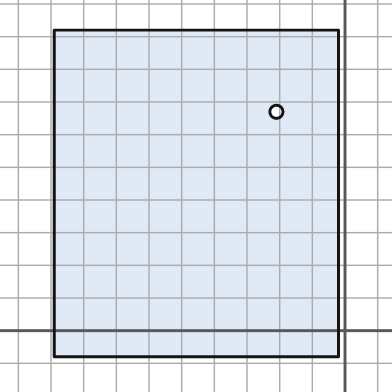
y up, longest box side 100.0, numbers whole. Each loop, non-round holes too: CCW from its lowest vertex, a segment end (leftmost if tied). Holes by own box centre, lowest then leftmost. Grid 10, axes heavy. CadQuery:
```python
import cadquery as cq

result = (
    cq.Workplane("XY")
    .moveTo(-89.0, -8.0)
    .lineTo(-2.0, -8.0)
    .lineTo(-2.0, 92.0)
    .lineTo(-89.0, 92.0)
    .close()
    .moveTo(-21.0, 67.0)
    .circle(2.0)
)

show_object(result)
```